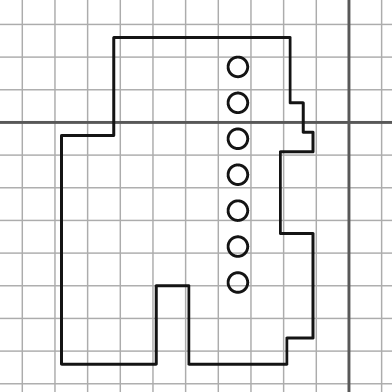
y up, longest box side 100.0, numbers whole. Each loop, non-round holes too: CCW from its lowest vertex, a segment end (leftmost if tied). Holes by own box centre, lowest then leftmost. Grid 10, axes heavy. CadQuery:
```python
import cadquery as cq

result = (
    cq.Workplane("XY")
    .moveTo(-88.0, -74.0)
    .lineTo(-59.0, -74.0)
    .lineTo(-59.0, -50.0)
    .lineTo(-49.0, -50.0)
    .lineTo(-49.0, -74.0)
    .lineTo(-19.0, -74.0)
    .lineTo(-19.0, -66.0)
    .lineTo(-11.0, -66.0)
    .lineTo(-11.0, -34.0)
    .lineTo(-21.0, -34.0)
    .lineTo(-21.0, -9.0)
    .lineTo(-11.0, -9.0)
    .lineTo(-11.0, -3.0)
    .lineTo(-14.0, -3.0)
    .lineTo(-14.0, 6.0)
    .lineTo(-18.0, 6.0)
    .lineTo(-18.0, 26.0)
    .lineTo(-72.0, 26.0)
    .lineTo(-72.0, -4.0)
    .lineTo(-88.0, -4.0)
    .close()
    .moveTo(-34.0, -49.0)
    .circle(3.0)
    .moveTo(-34.0, -38.0)
    .circle(3.0)
    .moveTo(-34.0, -27.0)
    .circle(3.0)
    .moveTo(-34.0, -16.0)
    .circle(3.0)
    .moveTo(-34.0, -5.0)
    .circle(3.0)
    .moveTo(-34.0, 6.0)
    .circle(3.0)
    .moveTo(-34.0, 17.0)
    .circle(3.0)
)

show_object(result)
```